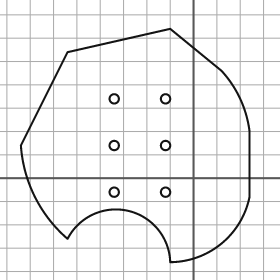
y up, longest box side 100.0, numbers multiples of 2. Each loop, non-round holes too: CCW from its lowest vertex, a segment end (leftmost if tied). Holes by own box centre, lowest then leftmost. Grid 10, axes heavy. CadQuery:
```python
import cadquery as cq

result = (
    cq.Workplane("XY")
    .moveTo(-10.0, -36.0)
    .threePointArc((12.0, -28.0), (24.0, -8.0))
    .lineTo(24.0, 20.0)
    .threePointArc((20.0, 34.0), (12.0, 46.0))
    .lineTo(-10.0, 64.0)
    .lineTo(-54.0, 54.0)
    .lineTo(-74.0, 14.0)
    .threePointArc((-68.0, -8.0), (-54.0, -26.0))
    .threePointArc((-28.0, -14.0), (-10.0, -36.0))
    .close()
    .moveTo(-34.0, -6.0)
    .circle(2.0)
    .moveTo(-12.0, -6.0)
    .circle(2.0)
    .moveTo(-34.0, 14.0)
    .circle(2.0)
    .moveTo(-12.0, 14.0)
    .circle(2.0)
    .moveTo(-34.0, 34.0)
    .circle(2.0)
    .moveTo(-12.0, 34.0)
    .circle(2.0)
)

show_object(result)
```